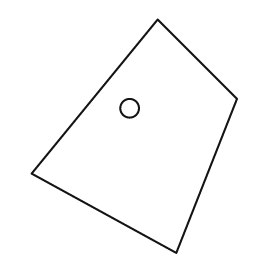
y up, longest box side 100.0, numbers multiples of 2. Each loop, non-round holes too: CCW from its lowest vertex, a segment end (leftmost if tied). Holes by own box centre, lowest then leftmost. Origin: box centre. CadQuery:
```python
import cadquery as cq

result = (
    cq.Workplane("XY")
    .moveTo(18.0, -50.0)
    .lineTo(44.0, 16.0)
    .lineTo(10.0, 50.0)
    .lineTo(-44.0, -16.0)
    .close()
    .moveTo(-2.0, 12.0)
    .circle(4.0)
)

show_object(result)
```